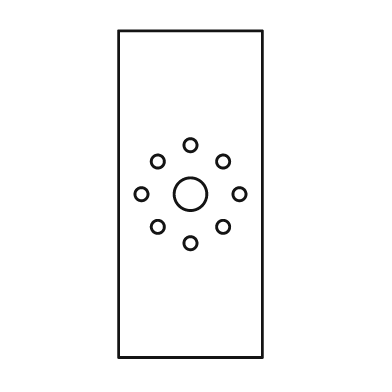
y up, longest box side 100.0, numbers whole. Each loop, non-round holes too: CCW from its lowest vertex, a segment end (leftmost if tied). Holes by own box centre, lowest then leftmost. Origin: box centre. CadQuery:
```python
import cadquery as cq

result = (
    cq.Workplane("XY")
    .moveTo(-22.0, -50.0)
    .lineTo(22.0, -50.0)
    .lineTo(22.0, 50.0)
    .lineTo(-22.0, 50.0)
    .close()
    .moveTo(0.0, -15.0)
    .circle(2.0)
    .moveTo(-10.0, -10.0)
    .circle(2.0)
    .moveTo(10.0, -10.0)
    .circle(2.0)
    .moveTo(-15.0, 0.0)
    .circle(2.0)
    .moveTo(0.0, 0.0)
    .circle(5.0)
    .moveTo(15.0, 0.0)
    .circle(2.0)
    .moveTo(-10.0, 10.0)
    .circle(2.0)
    .moveTo(10.0, 10.0)
    .circle(2.0)
    .moveTo(0.0, 15.0)
    .circle(2.0)
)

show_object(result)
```